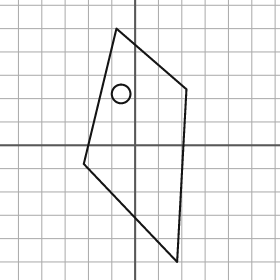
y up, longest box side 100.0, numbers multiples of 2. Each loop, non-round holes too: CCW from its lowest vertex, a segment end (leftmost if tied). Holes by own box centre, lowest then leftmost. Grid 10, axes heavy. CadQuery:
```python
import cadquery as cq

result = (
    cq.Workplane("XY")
    .moveTo(18.0, -50.0)
    .lineTo(22.0, 24.0)
    .lineTo(-8.0, 50.0)
    .lineTo(-22.0, -8.0)
    .close()
    .moveTo(-6.0, 22.0)
    .circle(4.0)
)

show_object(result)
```